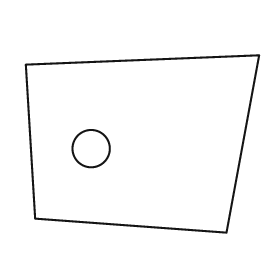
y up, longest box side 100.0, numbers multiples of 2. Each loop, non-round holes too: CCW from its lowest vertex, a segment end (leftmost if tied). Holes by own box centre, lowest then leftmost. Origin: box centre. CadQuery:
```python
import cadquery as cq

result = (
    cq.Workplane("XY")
    .moveTo(36.0, -38.0)
    .lineTo(50.0, 38.0)
    .lineTo(-50.0, 34.0)
    .lineTo(-46.0, -32.0)
    .close()
    .moveTo(-22.0, -2.0)
    .circle(8.0)
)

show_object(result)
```